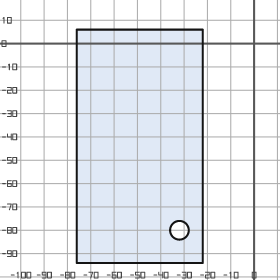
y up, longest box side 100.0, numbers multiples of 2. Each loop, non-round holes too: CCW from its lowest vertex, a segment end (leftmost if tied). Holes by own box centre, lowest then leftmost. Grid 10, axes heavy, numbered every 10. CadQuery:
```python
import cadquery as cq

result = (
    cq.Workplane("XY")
    .moveTo(-76.0, -94.0)
    .lineTo(-22.0, -94.0)
    .lineTo(-22.0, 6.0)
    .lineTo(-76.0, 6.0)
    .close()
    .moveTo(-32.0, -80.0)
    .circle(4.0)
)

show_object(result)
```